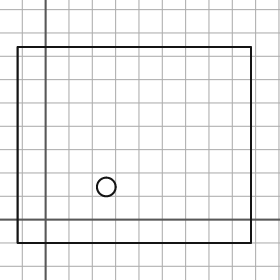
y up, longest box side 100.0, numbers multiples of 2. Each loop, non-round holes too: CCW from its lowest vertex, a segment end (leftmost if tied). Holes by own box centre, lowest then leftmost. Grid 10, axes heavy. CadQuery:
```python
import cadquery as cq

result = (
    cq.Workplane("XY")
    .moveTo(-12.0, -10.0)
    .lineTo(88.0, -10.0)
    .lineTo(88.0, 74.0)
    .lineTo(-12.0, 74.0)
    .close()
    .moveTo(26.0, 14.0)
    .circle(4.0)
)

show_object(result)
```